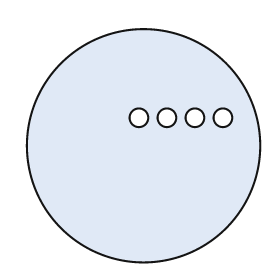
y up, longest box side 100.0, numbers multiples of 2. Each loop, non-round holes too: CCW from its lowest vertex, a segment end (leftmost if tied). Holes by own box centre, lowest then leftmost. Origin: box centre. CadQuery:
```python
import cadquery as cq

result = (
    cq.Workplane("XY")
    .moveTo(0.0, 0.0)
    .circle(50.0)
    .moveTo(-2.0, 12.0)
    .circle(4.0)
    .moveTo(10.0, 12.0)
    .circle(4.0)
    .moveTo(22.0, 12.0)
    .circle(4.0)
    .moveTo(34.0, 12.0)
    .circle(4.0)
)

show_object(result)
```